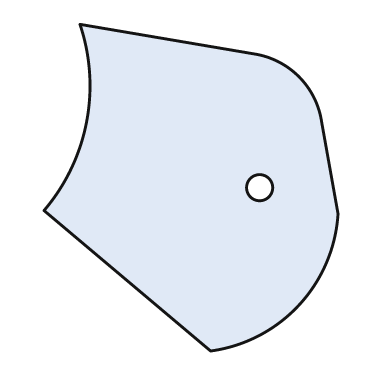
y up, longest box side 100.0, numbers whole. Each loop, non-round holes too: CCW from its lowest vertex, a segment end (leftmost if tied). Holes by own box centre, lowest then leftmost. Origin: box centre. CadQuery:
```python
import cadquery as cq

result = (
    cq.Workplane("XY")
    .moveTo(6.0, -50.0)
    .threePointArc((33.0, -36.0), (45.0, -8.0))
    .lineTo(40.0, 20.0)
    .threePointArc((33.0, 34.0), (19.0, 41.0))
    .lineTo(-34.0, 50.0)
    .threePointArc((-32.0, 20.0), (-45.0, -7.0))
    .close()
    .moveTo(21.0, 0.0)
    .circle(4.0)
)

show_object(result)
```